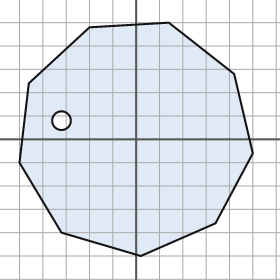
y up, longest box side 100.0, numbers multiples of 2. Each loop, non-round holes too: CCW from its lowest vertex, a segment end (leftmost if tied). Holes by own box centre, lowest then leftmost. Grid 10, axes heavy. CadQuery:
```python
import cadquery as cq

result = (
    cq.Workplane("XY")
    .moveTo(2.0, -50.0)
    .lineTo(34.0, -36.0)
    .lineTo(50.0, -6.0)
    .lineTo(42.0, 28.0)
    .lineTo(14.0, 50.0)
    .lineTo(-20.0, 48.0)
    .lineTo(-46.0, 24.0)
    .lineTo(-50.0, -10.0)
    .lineTo(-32.0, -40.0)
    .close()
    .moveTo(-32.0, 8.0)
    .circle(4.0)
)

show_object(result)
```